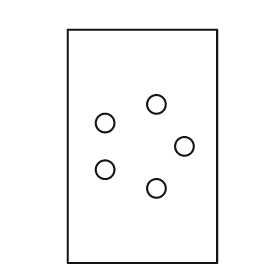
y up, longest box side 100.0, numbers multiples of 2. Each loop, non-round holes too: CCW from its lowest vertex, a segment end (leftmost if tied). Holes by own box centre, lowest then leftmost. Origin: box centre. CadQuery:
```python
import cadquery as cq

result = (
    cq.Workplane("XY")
    .moveTo(-32.0, -50.0)
    .lineTo(32.0, -50.0)
    .lineTo(32.0, 50.0)
    .lineTo(-32.0, 50.0)
    .close()
    .moveTo(6.0, -18.0)
    .circle(4.0)
    .moveTo(-16.0, -10.0)
    .circle(4.0)
    .moveTo(18.0, 0.0)
    .circle(4.0)
    .moveTo(-16.0, 10.0)
    .circle(4.0)
    .moveTo(6.0, 18.0)
    .circle(4.0)
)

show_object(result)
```